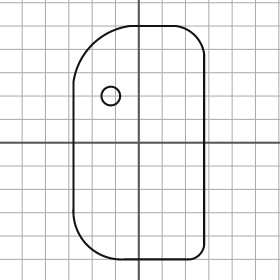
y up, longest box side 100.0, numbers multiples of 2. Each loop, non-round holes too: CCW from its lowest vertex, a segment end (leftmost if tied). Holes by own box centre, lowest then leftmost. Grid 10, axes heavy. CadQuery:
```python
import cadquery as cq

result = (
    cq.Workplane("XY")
    .moveTo(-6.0, -50.0)
    .lineTo(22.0, -50.0)
    .threePointArc((26.0, -48.0), (28.0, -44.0))
    .lineTo(28.0, 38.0)
    .threePointArc((24.0, 46.0), (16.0, 50.0))
    .lineTo(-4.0, 50.0)
    .threePointArc((-20.0, 42.0), (-28.0, 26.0))
    .lineTo(-28.0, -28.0)
    .threePointArc((-22.0, -44.0), (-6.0, -50.0))
    .close()
    .moveTo(-12.0, 20.0)
    .circle(4.0)
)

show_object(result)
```